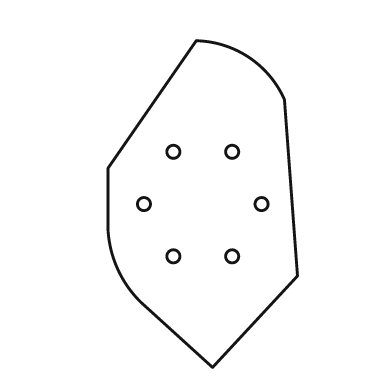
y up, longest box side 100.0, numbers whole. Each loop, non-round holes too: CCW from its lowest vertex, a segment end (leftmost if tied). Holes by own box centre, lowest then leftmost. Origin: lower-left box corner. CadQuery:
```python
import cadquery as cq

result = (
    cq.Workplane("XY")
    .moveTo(32.0, 0.0)
    .lineTo(58.0, 28.0)
    .lineTo(54.0, 82.0)
    .threePointArc((43.0, 95.0), (27.0, 100.0))
    .lineTo(0.0, 61.0)
    .lineTo(0.0, 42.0)
    .threePointArc((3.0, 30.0), (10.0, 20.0))
    .close()
    .moveTo(20.0, 34.0)
    .circle(2.0)
    .moveTo(38.0, 34.0)
    .circle(2.0)
    .moveTo(11.0, 50.0)
    .circle(2.0)
    .moveTo(47.0, 50.0)
    .circle(2.0)
    .moveTo(20.0, 66.0)
    .circle(2.0)
    .moveTo(38.0, 66.0)
    .circle(2.0)
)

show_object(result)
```